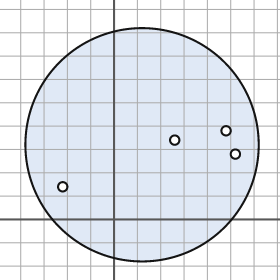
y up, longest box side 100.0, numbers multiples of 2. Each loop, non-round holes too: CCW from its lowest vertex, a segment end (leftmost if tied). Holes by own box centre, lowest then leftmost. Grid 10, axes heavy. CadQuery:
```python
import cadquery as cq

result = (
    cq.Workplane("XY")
    .moveTo(12.0, 32.0)
    .circle(50.0)
    .moveTo(-22.0, 14.0)
    .circle(2.0)
    .moveTo(52.0, 28.0)
    .circle(2.0)
    .moveTo(26.0, 34.0)
    .circle(2.0)
    .moveTo(48.0, 38.0)
    .circle(2.0)
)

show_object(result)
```